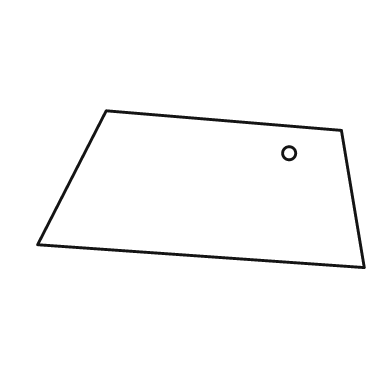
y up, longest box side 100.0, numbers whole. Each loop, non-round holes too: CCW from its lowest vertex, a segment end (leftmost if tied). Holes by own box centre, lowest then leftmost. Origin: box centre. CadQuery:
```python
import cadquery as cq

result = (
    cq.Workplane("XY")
    .moveTo(50.0, -24.0)
    .lineTo(43.0, 18.0)
    .lineTo(-29.0, 24.0)
    .lineTo(-50.0, -17.0)
    .close()
    .moveTo(27.0, 11.0)
    .circle(2.0)
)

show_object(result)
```